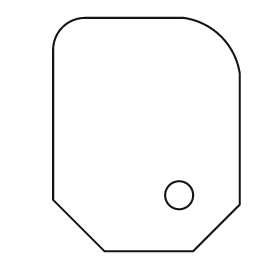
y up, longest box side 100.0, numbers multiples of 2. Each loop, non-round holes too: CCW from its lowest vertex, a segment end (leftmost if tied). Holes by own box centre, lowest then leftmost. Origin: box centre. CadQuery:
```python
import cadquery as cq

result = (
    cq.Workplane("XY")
    .moveTo(-18.0, -50.0)
    .lineTo(20.0, -50.0)
    .lineTo(40.0, -30.0)
    .lineTo(40.0, 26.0)
    .threePointArc((32.0, 42.0), (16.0, 50.0))
    .lineTo(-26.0, 50.0)
    .threePointArc((-36.0, 46.0), (-40.0, 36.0))
    .lineTo(-40.0, -28.0)
    .close()
    .moveTo(14.0, -26.0)
    .circle(6.0)
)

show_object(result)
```